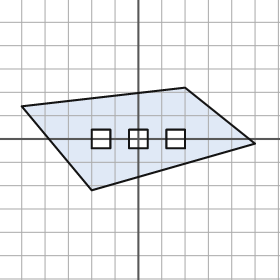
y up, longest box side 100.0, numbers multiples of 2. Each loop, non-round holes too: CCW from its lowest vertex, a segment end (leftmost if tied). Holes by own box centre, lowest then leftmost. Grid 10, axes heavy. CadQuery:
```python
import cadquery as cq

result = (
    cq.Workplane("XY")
    .moveTo(-20.0, -22.0)
    .lineTo(50.0, -2.0)
    .lineTo(20.0, 22.0)
    .lineTo(-50.0, 14.0)
    .close()
    .moveTo(-20.0, -4.0)
    .lineTo(-12.0, -4.0)
    .lineTo(-12.0, 4.0)
    .lineTo(-20.0, 4.0)
    .close()
    .moveTo(-4.0, -4.0)
    .lineTo(4.0, -4.0)
    .lineTo(4.0, 4.0)
    .lineTo(-4.0, 4.0)
    .close()
    .moveTo(12.0, -4.0)
    .lineTo(20.0, -4.0)
    .lineTo(20.0, 4.0)
    .lineTo(12.0, 4.0)
    .close()
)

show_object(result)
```